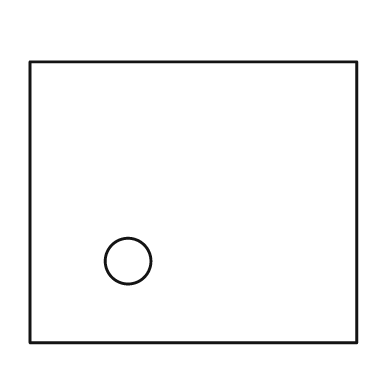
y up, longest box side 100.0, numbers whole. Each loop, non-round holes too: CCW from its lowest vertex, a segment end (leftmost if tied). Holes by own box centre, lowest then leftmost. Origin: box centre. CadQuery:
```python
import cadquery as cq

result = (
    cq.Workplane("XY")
    .moveTo(-50.0, -43.0)
    .lineTo(50.0, -43.0)
    .lineTo(50.0, 43.0)
    .lineTo(-50.0, 43.0)
    .close()
    .moveTo(-20.0, -18.0)
    .circle(7.0)
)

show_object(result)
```